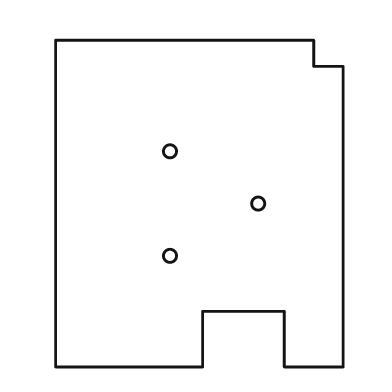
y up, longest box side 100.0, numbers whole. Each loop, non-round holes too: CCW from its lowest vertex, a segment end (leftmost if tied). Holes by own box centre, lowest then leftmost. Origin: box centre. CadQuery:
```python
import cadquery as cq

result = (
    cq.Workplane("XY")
    .moveTo(-44.0, -50.0)
    .lineTo(1.0, -50.0)
    .lineTo(1.0, -33.0)
    .lineTo(26.0, -33.0)
    .lineTo(26.0, -50.0)
    .lineTo(44.0, -50.0)
    .lineTo(44.0, 42.0)
    .lineTo(35.0, 42.0)
    .lineTo(35.0, 50.0)
    .lineTo(-44.0, 50.0)
    .close()
    .moveTo(-9.0, -16.0)
    .circle(2.0)
    .moveTo(18.0, 0.0)
    .circle(2.0)
    .moveTo(-9.0, 16.0)
    .circle(2.0)
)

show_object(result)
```